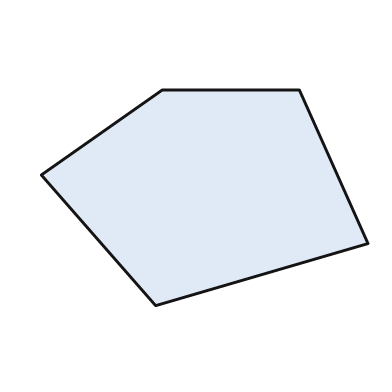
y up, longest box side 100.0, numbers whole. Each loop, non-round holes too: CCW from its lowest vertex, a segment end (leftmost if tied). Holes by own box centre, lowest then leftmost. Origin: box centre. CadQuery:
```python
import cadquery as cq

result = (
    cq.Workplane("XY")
    .moveTo(-15.0, -33.0)
    .lineTo(50.0, -14.0)
    .lineTo(29.0, 33.0)
    .lineTo(-13.0, 33.0)
    .lineTo(-50.0, 7.0)
    .close()
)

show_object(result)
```